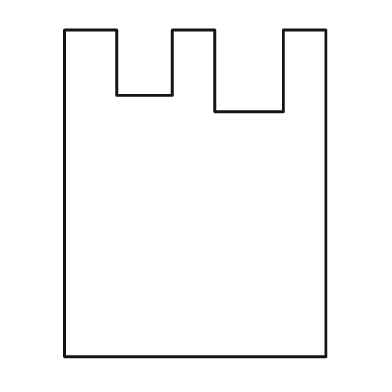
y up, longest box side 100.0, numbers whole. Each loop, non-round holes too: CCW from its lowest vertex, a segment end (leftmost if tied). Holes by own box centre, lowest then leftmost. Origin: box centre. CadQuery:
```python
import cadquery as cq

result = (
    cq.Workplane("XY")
    .moveTo(-40.0, -50.0)
    .lineTo(40.0, -50.0)
    .lineTo(40.0, 50.0)
    .lineTo(27.0, 50.0)
    .lineTo(27.0, 25.0)
    .lineTo(6.0, 25.0)
    .lineTo(6.0, 50.0)
    .lineTo(-7.0, 50.0)
    .lineTo(-7.0, 30.0)
    .lineTo(-24.0, 30.0)
    .lineTo(-24.0, 50.0)
    .lineTo(-40.0, 50.0)
    .close()
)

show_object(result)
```